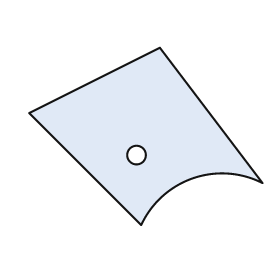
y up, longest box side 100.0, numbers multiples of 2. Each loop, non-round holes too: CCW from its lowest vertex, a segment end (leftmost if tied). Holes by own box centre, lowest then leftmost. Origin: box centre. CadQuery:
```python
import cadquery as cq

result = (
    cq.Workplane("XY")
    .moveTo(-2.0, -38.0)
    .threePointArc((20.0, -18.0), (50.0, -20.0))
    .lineTo(6.0, 38.0)
    .lineTo(-50.0, 10.0)
    .close()
    .moveTo(-4.0, -8.0)
    .circle(4.0)
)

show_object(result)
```